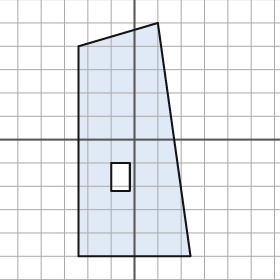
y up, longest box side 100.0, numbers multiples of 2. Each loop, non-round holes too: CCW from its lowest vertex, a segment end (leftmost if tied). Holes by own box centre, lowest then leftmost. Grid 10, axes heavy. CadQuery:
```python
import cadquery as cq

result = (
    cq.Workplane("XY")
    .moveTo(-24.0, -50.0)
    .lineTo(24.0, -50.0)
    .lineTo(10.0, 50.0)
    .lineTo(-24.0, 40.0)
    .close()
    .moveTo(-10.0, -22.0)
    .lineTo(-2.0, -22.0)
    .lineTo(-2.0, -10.0)
    .lineTo(-10.0, -10.0)
    .close()
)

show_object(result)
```